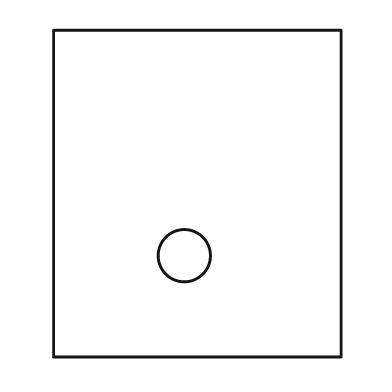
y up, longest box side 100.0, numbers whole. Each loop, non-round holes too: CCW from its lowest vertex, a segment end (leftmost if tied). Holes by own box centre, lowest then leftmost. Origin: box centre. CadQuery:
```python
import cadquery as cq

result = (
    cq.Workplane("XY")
    .moveTo(-44.0, -50.0)
    .lineTo(44.0, -50.0)
    .lineTo(44.0, 50.0)
    .lineTo(-44.0, 50.0)
    .close()
    .moveTo(-4.0, -19.0)
    .circle(8.0)
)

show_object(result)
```